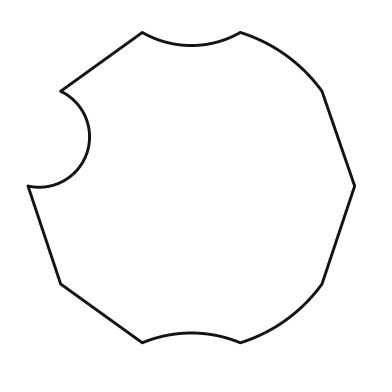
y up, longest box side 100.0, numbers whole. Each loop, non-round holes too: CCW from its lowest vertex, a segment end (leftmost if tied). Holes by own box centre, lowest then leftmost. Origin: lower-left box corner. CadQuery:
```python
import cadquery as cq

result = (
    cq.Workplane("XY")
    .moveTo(35.0, 0.0)
    .threePointArc((50.0, 3.0), (65.0, 0.0))
    .threePointArc((79.0, 7.0), (90.0, 18.0))
    .lineTo(100.0, 48.0)
    .lineTo(90.0, 77.0)
    .threePointArc((79.0, 88.0), (65.0, 95.0))
    .threePointArc((50.0, 91.0), (35.0, 95.0))
    .lineTo(10.0, 77.0)
    .threePointArc((18.0, 58.0), (0.0, 48.0))
    .lineTo(10.0, 18.0)
    .close()
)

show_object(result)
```